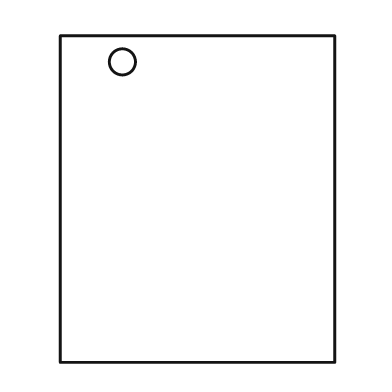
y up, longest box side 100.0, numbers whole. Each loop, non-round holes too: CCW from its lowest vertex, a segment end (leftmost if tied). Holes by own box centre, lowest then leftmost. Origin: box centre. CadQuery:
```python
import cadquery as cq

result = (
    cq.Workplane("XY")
    .moveTo(-42.0, -50.0)
    .lineTo(42.0, -50.0)
    .lineTo(42.0, 50.0)
    .lineTo(-42.0, 50.0)
    .close()
    .moveTo(-23.0, 42.0)
    .circle(4.0)
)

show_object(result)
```